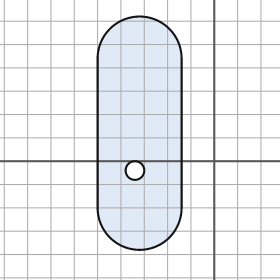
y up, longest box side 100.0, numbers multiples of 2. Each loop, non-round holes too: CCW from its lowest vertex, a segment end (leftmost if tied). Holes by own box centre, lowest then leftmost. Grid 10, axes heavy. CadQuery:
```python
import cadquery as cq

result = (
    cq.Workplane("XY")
    .moveTo(-50.0, -20.0)
    .threePointArc((-32.0, -38.0), (-14.0, -20.0))
    .lineTo(-14.0, 44.0)
    .threePointArc((-32.0, 62.0), (-50.0, 44.0))
    .close()
    .moveTo(-34.0, -4.0)
    .circle(4.0)
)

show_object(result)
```